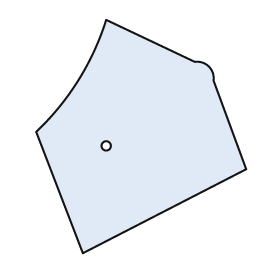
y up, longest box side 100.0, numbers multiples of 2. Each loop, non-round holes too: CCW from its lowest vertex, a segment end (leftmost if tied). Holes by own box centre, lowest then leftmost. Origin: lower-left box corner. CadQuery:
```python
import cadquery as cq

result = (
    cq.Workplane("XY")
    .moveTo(20.0, 0.0)
    .lineTo(90.0, 36.0)
    .lineTo(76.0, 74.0)
    .threePointArc((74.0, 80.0), (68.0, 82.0))
    .lineTo(30.0, 100.0)
    .threePointArc((18.0, 74.0), (0.0, 52.0))
    .close()
    .moveTo(30.0, 46.0)
    .circle(2.0)
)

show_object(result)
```